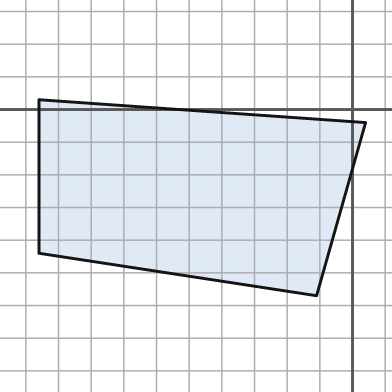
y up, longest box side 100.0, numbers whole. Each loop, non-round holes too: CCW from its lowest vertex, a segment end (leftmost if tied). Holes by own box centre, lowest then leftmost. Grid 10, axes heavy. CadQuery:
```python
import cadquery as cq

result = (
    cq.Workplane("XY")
    .moveTo(-11.0, -57.0)
    .lineTo(4.0, -4.0)
    .lineTo(-96.0, 3.0)
    .lineTo(-96.0, -44.0)
    .close()
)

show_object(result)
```